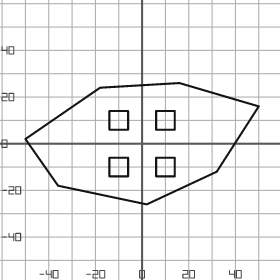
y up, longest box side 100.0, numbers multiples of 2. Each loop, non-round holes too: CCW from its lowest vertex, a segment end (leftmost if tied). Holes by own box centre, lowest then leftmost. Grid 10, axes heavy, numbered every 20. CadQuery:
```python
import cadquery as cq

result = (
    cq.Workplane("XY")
    .moveTo(2.0, -26.0)
    .lineTo(32.0, -12.0)
    .lineTo(50.0, 16.0)
    .lineTo(16.0, 26.0)
    .lineTo(-18.0, 24.0)
    .lineTo(-50.0, 2.0)
    .lineTo(-36.0, -18.0)
    .close()
    .moveTo(-14.0, -14.0)
    .lineTo(-6.0, -14.0)
    .lineTo(-6.0, -6.0)
    .lineTo(-14.0, -6.0)
    .close()
    .moveTo(6.0, -14.0)
    .lineTo(14.0, -14.0)
    .lineTo(14.0, -6.0)
    .lineTo(6.0, -6.0)
    .close()
    .moveTo(-14.0, 6.0)
    .lineTo(-6.0, 6.0)
    .lineTo(-6.0, 14.0)
    .lineTo(-14.0, 14.0)
    .close()
    .moveTo(6.0, 6.0)
    .lineTo(14.0, 6.0)
    .lineTo(14.0, 14.0)
    .lineTo(6.0, 14.0)
    .close()
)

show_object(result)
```